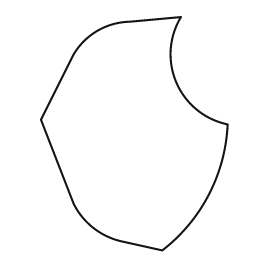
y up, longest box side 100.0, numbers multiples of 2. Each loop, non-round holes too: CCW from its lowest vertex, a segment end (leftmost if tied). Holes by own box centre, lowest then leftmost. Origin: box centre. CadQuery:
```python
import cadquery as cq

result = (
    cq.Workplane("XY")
    .moveTo(12.0, -50.0)
    .threePointArc((32.0, -26.0), (40.0, 4.0))
    .threePointArc((18.0, 22.0), (20.0, 50.0))
    .lineTo(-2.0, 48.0)
    .threePointArc((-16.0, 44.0), (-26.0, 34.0))
    .lineTo(-40.0, 6.0)
    .lineTo(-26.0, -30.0)
    .threePointArc((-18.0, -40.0), (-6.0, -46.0))
    .close()
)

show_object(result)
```